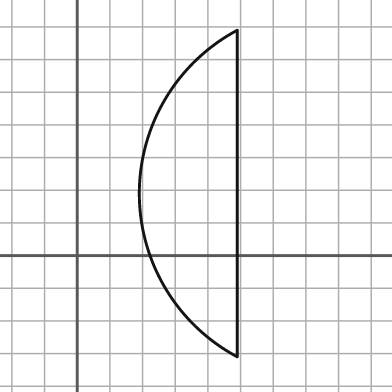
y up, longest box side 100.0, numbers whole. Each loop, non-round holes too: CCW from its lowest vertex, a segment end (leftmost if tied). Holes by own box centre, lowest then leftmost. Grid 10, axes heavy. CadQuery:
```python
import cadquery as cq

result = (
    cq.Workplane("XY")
    .moveTo(49.0, -31.0)
    .lineTo(49.0, 69.0)
    .threePointArc((19.0, 19.0), (49.0, -31.0))
    .close()
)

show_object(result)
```